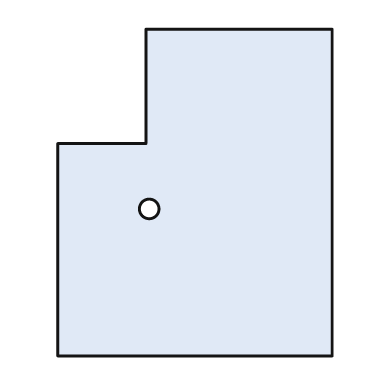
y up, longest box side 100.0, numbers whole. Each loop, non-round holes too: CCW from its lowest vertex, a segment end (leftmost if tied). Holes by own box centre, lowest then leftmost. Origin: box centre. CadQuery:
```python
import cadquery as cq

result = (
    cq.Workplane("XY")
    .moveTo(-42.0, -50.0)
    .lineTo(42.0, -50.0)
    .lineTo(42.0, 50.0)
    .lineTo(-15.0, 50.0)
    .lineTo(-15.0, 15.0)
    .lineTo(-42.0, 15.0)
    .close()
    .moveTo(-14.0, -5.0)
    .circle(3.0)
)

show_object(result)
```